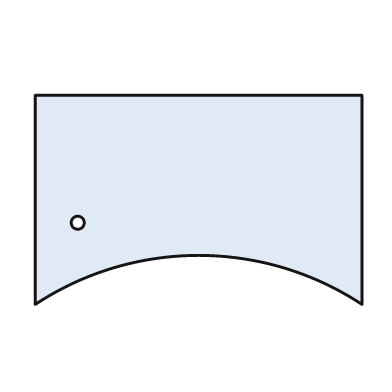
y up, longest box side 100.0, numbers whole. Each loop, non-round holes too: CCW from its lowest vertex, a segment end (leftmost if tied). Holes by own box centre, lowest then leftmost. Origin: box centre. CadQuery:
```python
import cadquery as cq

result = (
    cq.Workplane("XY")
    .moveTo(-50.0, -32.0)
    .threePointArc((0.0, -17.0), (50.0, -32.0))
    .lineTo(50.0, 32.0)
    .lineTo(-50.0, 32.0)
    .close()
    .moveTo(-37.0, -7.0)
    .circle(2.0)
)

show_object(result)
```